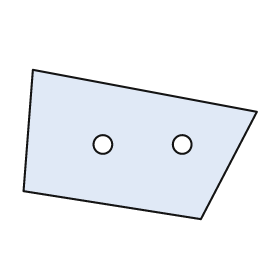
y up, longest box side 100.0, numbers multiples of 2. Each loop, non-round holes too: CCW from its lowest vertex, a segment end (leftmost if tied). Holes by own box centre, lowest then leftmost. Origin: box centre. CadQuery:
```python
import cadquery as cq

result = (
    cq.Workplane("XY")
    .moveTo(26.0, -32.0)
    .lineTo(50.0, 14.0)
    .lineTo(-46.0, 32.0)
    .lineTo(-50.0, -20.0)
    .close()
    .moveTo(-16.0, 0.0)
    .circle(4.0)
    .moveTo(18.0, 0.0)
    .circle(4.0)
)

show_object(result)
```